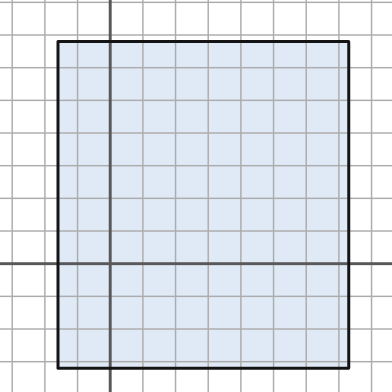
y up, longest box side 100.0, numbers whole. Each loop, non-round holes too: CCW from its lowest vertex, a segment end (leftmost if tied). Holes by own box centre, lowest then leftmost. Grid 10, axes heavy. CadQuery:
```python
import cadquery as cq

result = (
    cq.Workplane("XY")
    .moveTo(-16.0, -32.0)
    .lineTo(73.0, -32.0)
    .lineTo(73.0, 68.0)
    .lineTo(-16.0, 68.0)
    .close()
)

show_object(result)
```